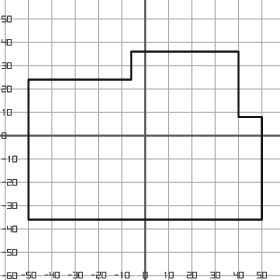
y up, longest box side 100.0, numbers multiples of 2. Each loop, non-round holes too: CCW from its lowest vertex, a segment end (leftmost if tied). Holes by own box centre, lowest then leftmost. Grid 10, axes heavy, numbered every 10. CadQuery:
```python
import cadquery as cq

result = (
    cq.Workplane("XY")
    .moveTo(-50.0, -36.0)
    .lineTo(50.0, -36.0)
    .lineTo(50.0, 8.0)
    .lineTo(40.0, 8.0)
    .lineTo(40.0, 36.0)
    .lineTo(-6.0, 36.0)
    .lineTo(-6.0, 24.0)
    .lineTo(-50.0, 24.0)
    .close()
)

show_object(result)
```